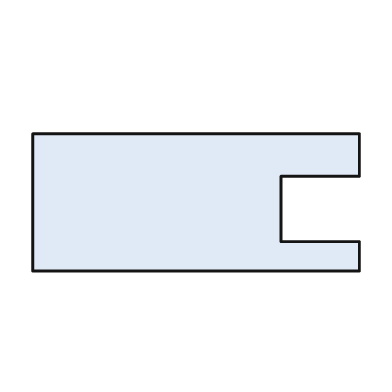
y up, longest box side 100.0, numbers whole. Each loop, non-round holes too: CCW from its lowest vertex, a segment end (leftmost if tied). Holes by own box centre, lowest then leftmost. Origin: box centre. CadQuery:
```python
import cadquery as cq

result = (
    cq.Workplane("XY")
    .moveTo(-50.0, -21.0)
    .lineTo(50.0, -21.0)
    .lineTo(50.0, -12.0)
    .lineTo(26.0, -12.0)
    .lineTo(26.0, 8.0)
    .lineTo(50.0, 8.0)
    .lineTo(50.0, 21.0)
    .lineTo(-50.0, 21.0)
    .close()
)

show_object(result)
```